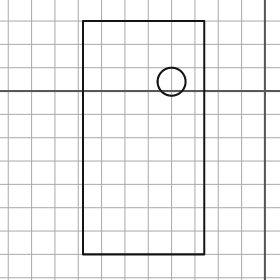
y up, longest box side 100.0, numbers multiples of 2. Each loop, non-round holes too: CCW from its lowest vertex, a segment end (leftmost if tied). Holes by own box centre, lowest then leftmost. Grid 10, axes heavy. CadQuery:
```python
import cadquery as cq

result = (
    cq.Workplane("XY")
    .moveTo(-78.0, -70.0)
    .lineTo(-26.0, -70.0)
    .lineTo(-26.0, 30.0)
    .lineTo(-78.0, 30.0)
    .close()
    .moveTo(-40.0, 4.0)
    .circle(6.0)
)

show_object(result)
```